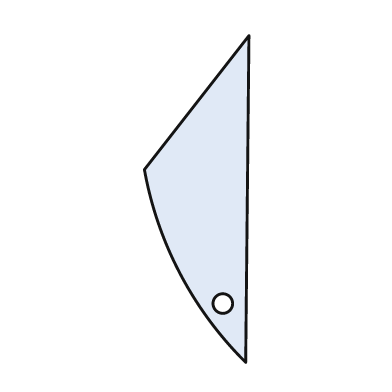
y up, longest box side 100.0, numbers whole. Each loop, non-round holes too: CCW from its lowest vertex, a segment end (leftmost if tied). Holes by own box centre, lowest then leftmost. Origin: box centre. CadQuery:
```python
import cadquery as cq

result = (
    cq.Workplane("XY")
    .moveTo(15.0, -50.0)
    .lineTo(16.0, 50.0)
    .lineTo(-16.0, 9.0)
    .threePointArc((-5.0, -23.0), (15.0, -50.0))
    .close()
    .moveTo(8.0, -32.0)
    .circle(3.0)
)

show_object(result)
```